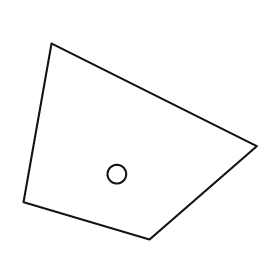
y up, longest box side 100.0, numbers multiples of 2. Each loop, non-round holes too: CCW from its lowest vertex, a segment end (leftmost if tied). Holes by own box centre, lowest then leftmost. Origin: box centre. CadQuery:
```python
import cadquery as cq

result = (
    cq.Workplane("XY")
    .moveTo(4.0, -42.0)
    .lineTo(50.0, -2.0)
    .lineTo(-38.0, 42.0)
    .lineTo(-50.0, -26.0)
    .close()
    .moveTo(-10.0, -14.0)
    .circle(4.0)
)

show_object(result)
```